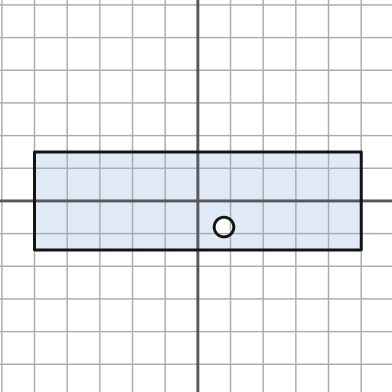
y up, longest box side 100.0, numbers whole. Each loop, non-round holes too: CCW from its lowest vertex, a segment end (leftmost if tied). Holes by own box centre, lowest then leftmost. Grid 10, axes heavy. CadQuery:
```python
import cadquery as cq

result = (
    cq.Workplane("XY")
    .moveTo(-50.0, -15.0)
    .lineTo(50.0, -15.0)
    .lineTo(50.0, 15.0)
    .lineTo(-50.0, 15.0)
    .close()
    .moveTo(8.0, -8.0)
    .circle(3.0)
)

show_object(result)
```